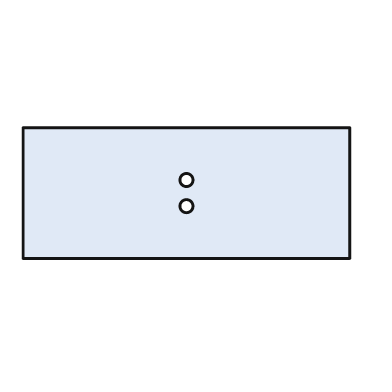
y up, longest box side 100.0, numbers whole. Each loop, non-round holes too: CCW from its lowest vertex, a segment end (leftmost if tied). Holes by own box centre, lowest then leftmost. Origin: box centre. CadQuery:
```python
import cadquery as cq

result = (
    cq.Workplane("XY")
    .moveTo(-50.0, -20.0)
    .lineTo(50.0, -20.0)
    .lineTo(50.0, 20.0)
    .lineTo(-50.0, 20.0)
    .close()
    .moveTo(0.0, -4.0)
    .circle(2.0)
    .moveTo(0.0, 4.0)
    .circle(2.0)
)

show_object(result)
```